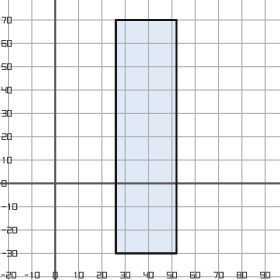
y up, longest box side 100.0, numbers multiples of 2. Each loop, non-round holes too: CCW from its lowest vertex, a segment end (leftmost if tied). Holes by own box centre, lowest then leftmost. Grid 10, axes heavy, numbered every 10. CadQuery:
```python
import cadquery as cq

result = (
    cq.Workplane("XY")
    .moveTo(26.0, -30.0)
    .lineTo(52.0, -30.0)
    .lineTo(52.0, 70.0)
    .lineTo(26.0, 70.0)
    .close()
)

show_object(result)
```